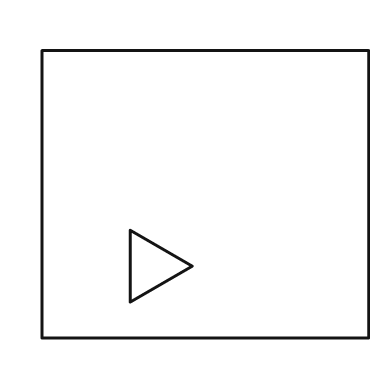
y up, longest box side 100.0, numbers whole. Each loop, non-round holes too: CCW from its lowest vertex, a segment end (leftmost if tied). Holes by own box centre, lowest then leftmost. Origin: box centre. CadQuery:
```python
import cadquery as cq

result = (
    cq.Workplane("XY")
    .moveTo(-50.0, -44.0)
    .lineTo(50.0, -44.0)
    .lineTo(50.0, 44.0)
    .lineTo(-50.0, 44.0)
    .close()
    .moveTo(-23.0, -33.0)
    .lineTo(-4.0, -22.0)
    .lineTo(-23.0, -11.0)
    .close()
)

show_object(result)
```